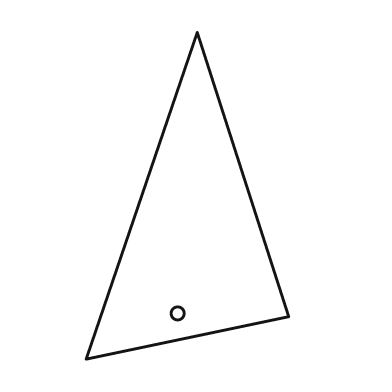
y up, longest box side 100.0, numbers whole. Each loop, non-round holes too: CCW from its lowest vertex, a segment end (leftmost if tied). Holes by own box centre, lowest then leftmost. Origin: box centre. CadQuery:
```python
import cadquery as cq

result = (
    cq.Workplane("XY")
    .moveTo(-31.0, -50.0)
    .lineTo(31.0, -37.0)
    .lineTo(3.0, 50.0)
    .close()
    .moveTo(-3.0, -36.0)
    .circle(2.0)
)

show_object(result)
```